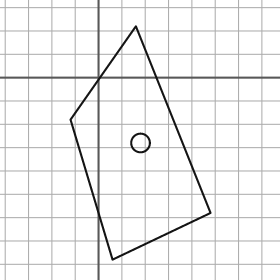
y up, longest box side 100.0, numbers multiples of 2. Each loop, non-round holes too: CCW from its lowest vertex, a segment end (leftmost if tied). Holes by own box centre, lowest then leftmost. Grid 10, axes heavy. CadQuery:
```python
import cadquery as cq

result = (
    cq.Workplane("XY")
    .moveTo(6.0, -78.0)
    .lineTo(48.0, -58.0)
    .lineTo(16.0, 22.0)
    .lineTo(-12.0, -18.0)
    .close()
    .moveTo(18.0, -28.0)
    .circle(4.0)
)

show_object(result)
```